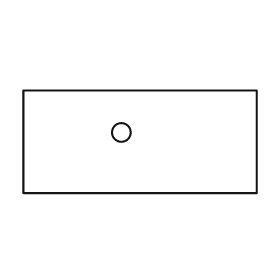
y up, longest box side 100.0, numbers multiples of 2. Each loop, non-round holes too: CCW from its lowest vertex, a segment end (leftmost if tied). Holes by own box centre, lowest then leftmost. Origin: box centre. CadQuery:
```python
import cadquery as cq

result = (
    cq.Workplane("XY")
    .moveTo(-50.0, -22.0)
    .lineTo(50.0, -22.0)
    .lineTo(50.0, 22.0)
    .lineTo(-50.0, 22.0)
    .close()
    .moveTo(-8.0, 4.0)
    .circle(4.0)
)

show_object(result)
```